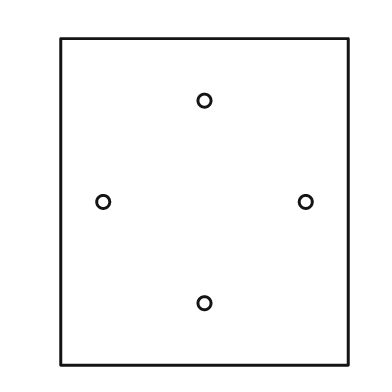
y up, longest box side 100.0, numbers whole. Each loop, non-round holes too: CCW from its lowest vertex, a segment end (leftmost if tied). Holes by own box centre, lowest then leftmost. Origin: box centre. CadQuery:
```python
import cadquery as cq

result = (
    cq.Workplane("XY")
    .moveTo(-44.0, -50.0)
    .lineTo(44.0, -50.0)
    .lineTo(44.0, 50.0)
    .lineTo(-44.0, 50.0)
    .close()
    .moveTo(0.0, -31.0)
    .circle(2.0)
    .moveTo(-31.0, 0.0)
    .circle(2.0)
    .moveTo(31.0, 0.0)
    .circle(2.0)
    .moveTo(0.0, 31.0)
    .circle(2.0)
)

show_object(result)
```